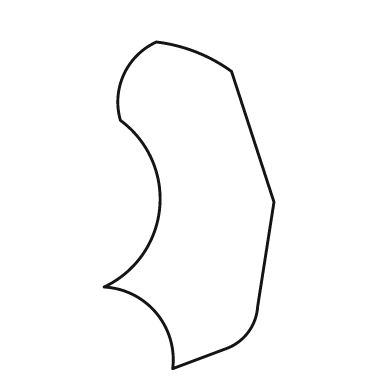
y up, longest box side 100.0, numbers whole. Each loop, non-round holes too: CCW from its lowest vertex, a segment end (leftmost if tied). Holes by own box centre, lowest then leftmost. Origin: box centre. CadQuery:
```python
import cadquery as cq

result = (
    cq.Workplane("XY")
    .moveTo(-5.0, -50.0)
    .lineTo(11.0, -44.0)
    .threePointArc((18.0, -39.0), (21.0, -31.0))
    .lineTo(26.0, 1.0)
    .lineTo(13.0, 41.0)
    .threePointArc((2.0, 47.0), (-10.0, 50.0))
    .threePointArc((-20.0, 40.0), (-21.0, 26.0))
    .threePointArc((-9.0, -1.0), (-26.0, -25.0))
    .threePointArc((-10.0, -33.0), (-5.0, -50.0))
    .close()
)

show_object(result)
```